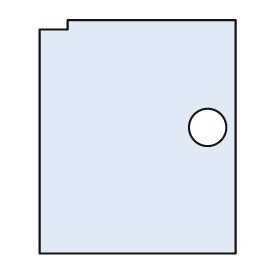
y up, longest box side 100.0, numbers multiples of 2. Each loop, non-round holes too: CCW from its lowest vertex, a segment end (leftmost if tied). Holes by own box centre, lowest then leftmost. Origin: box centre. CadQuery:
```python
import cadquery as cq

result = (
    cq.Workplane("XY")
    .moveTo(-42.0, -50.0)
    .lineTo(42.0, -50.0)
    .lineTo(42.0, 50.0)
    .lineTo(-30.0, 50.0)
    .lineTo(-30.0, 46.0)
    .lineTo(-42.0, 46.0)
    .close()
    .moveTo(30.0, 4.0)
    .circle(8.0)
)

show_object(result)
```